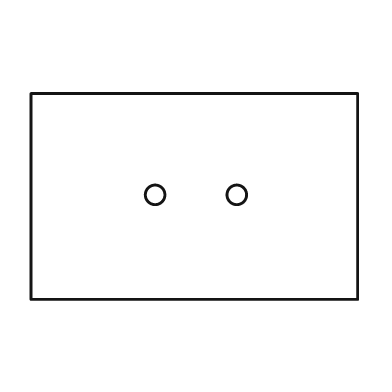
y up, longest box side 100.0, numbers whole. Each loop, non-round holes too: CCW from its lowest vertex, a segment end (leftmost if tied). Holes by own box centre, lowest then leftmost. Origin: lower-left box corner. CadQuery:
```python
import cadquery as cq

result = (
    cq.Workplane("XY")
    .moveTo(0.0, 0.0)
    .lineTo(100.0, 0.0)
    .lineTo(100.0, 63.0)
    .lineTo(0.0, 63.0)
    .close()
    .moveTo(38.0, 32.0)
    .circle(3.0)
    .moveTo(63.0, 32.0)
    .circle(3.0)
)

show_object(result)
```